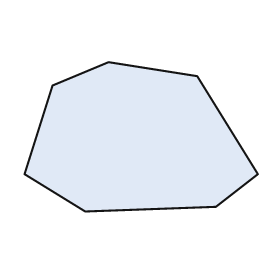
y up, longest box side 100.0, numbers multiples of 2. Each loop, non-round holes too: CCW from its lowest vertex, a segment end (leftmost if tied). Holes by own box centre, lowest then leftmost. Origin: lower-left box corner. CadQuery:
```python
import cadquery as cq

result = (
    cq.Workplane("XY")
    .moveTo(26.0, 0.0)
    .lineTo(82.0, 2.0)
    .lineTo(100.0, 16.0)
    .lineTo(74.0, 58.0)
    .lineTo(36.0, 64.0)
    .lineTo(12.0, 54.0)
    .lineTo(0.0, 16.0)
    .close()
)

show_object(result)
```